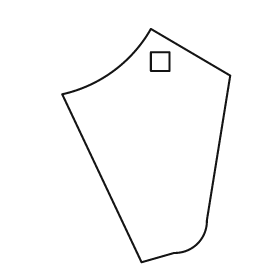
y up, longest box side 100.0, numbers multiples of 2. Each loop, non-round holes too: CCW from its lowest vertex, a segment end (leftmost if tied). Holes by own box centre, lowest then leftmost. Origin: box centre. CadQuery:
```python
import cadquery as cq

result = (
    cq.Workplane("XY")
    .moveTo(-2.0, -50.0)
    .lineTo(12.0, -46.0)
    .threePointArc((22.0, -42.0), (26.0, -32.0))
    .lineTo(36.0, 30.0)
    .lineTo(2.0, 50.0)
    .threePointArc((-14.0, 32.0), (-36.0, 22.0))
    .close()
    .moveTo(2.0, 32.0)
    .lineTo(10.0, 32.0)
    .lineTo(10.0, 40.0)
    .lineTo(2.0, 40.0)
    .close()
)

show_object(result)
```